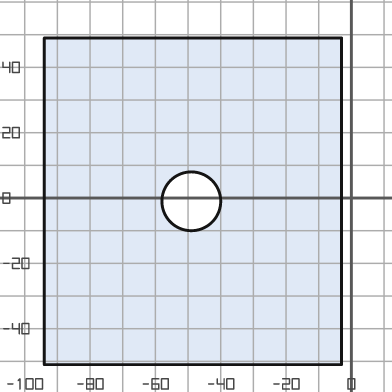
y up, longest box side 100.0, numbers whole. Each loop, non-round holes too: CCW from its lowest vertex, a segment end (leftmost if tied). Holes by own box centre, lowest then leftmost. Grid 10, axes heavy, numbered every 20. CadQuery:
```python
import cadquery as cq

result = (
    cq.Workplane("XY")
    .moveTo(-94.0, -51.0)
    .lineTo(-3.0, -51.0)
    .lineTo(-3.0, 49.0)
    .lineTo(-94.0, 49.0)
    .close()
    .moveTo(-49.0, -1.0)
    .circle(9.0)
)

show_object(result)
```